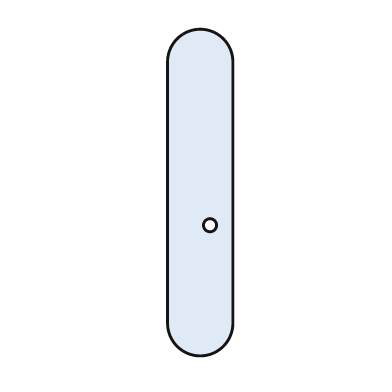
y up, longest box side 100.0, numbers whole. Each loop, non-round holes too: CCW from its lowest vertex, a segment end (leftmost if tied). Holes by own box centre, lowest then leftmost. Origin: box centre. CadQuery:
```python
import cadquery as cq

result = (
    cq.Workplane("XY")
    .moveTo(-10.0, -40.0)
    .threePointArc((0.0, -50.0), (10.0, -40.0))
    .lineTo(10.0, 40.0)
    .threePointArc((0.0, 50.0), (-10.0, 40.0))
    .close()
    .moveTo(3.0, -10.0)
    .circle(2.0)
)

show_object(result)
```